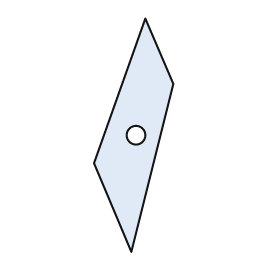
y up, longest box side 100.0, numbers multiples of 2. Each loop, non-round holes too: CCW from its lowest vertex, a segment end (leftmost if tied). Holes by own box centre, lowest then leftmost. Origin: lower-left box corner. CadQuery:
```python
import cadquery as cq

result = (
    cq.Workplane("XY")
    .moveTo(16.0, 0.0)
    .lineTo(34.0, 72.0)
    .lineTo(22.0, 100.0)
    .lineTo(0.0, 38.0)
    .close()
    .moveTo(18.0, 50.0)
    .circle(4.0)
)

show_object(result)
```